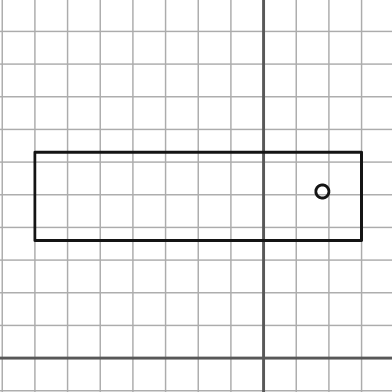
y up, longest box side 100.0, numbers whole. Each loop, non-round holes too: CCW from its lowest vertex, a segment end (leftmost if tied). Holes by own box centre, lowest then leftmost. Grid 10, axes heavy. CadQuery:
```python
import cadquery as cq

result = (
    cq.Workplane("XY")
    .moveTo(-70.0, 36.0)
    .lineTo(30.0, 36.0)
    .lineTo(30.0, 63.0)
    .lineTo(-70.0, 63.0)
    .close()
    .moveTo(18.0, 51.0)
    .circle(2.0)
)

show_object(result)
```